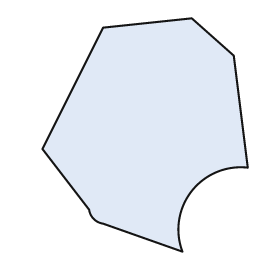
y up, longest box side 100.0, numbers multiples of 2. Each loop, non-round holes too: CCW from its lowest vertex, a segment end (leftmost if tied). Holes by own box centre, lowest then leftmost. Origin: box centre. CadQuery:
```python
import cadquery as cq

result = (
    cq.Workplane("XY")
    .moveTo(16.0, -50.0)
    .threePointArc((20.0, -24.0), (44.0, -14.0))
    .lineTo(38.0, 34.0)
    .lineTo(20.0, 50.0)
    .lineTo(-18.0, 46.0)
    .lineTo(-44.0, -6.0)
    .lineTo(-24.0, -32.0)
    .threePointArc((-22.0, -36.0), (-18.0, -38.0))
    .close()
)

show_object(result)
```